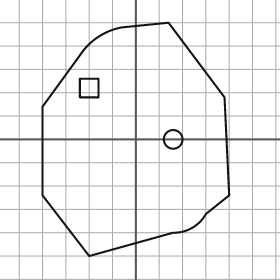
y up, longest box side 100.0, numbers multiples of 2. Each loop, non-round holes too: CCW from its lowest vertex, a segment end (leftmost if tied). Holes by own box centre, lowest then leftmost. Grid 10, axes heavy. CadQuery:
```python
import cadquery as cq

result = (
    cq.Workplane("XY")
    .moveTo(-20.0, -50.0)
    .lineTo(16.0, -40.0)
    .threePointArc((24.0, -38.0), (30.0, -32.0))
    .lineTo(40.0, -24.0)
    .lineTo(38.0, 18.0)
    .lineTo(14.0, 50.0)
    .lineTo(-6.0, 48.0)
    .threePointArc((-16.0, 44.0), (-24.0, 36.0))
    .lineTo(-40.0, 14.0)
    .lineTo(-40.0, -24.0)
    .close()
    .moveTo(16.0, 0.0)
    .circle(4.0)
    .moveTo(-24.0, 18.0)
    .lineTo(-16.0, 18.0)
    .lineTo(-16.0, 26.0)
    .lineTo(-24.0, 26.0)
    .close()
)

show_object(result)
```